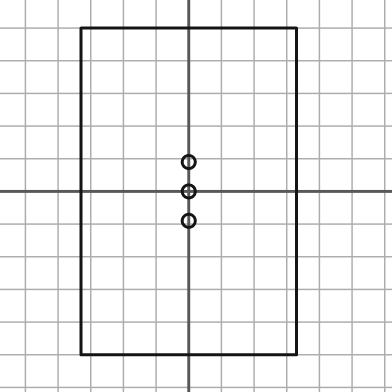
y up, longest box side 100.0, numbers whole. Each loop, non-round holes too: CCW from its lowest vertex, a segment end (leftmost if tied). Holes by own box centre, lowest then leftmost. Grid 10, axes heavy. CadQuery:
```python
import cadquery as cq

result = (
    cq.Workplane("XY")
    .moveTo(-33.0, -50.0)
    .lineTo(33.0, -50.0)
    .lineTo(33.0, 50.0)
    .lineTo(-33.0, 50.0)
    .close()
    .moveTo(0.0, -9.0)
    .circle(2.0)
    .moveTo(0.0, 0.0)
    .circle(2.0)
    .moveTo(0.0, 9.0)
    .circle(2.0)
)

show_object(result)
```